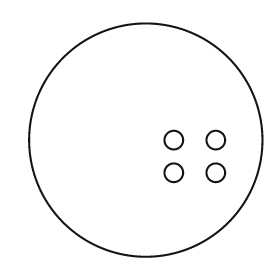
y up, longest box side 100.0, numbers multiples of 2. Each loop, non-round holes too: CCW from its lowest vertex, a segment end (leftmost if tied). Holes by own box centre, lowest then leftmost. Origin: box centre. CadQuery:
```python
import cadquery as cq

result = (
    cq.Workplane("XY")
    .moveTo(0.0, 0.0)
    .circle(50.0)
    .moveTo(12.0, -14.0)
    .circle(4.0)
    .moveTo(30.0, -14.0)
    .circle(4.0)
    .moveTo(12.0, 0.0)
    .circle(4.0)
    .moveTo(30.0, 0.0)
    .circle(4.0)
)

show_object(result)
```